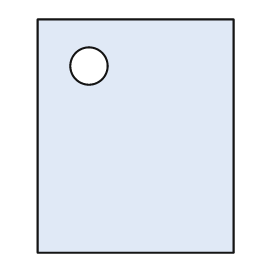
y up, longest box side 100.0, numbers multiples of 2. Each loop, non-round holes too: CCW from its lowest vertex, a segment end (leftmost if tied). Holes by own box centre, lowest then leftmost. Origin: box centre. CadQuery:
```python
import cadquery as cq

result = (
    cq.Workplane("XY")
    .moveTo(-42.0, -50.0)
    .lineTo(42.0, -50.0)
    .lineTo(42.0, 50.0)
    .lineTo(-42.0, 50.0)
    .close()
    .moveTo(-20.0, 30.0)
    .circle(8.0)
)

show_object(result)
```